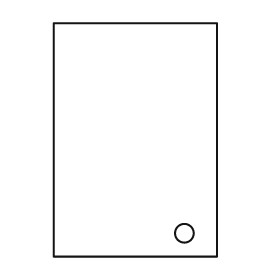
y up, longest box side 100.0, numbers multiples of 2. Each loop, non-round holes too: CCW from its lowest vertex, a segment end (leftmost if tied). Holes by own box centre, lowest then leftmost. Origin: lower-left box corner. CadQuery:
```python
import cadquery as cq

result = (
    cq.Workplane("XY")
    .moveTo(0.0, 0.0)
    .lineTo(70.0, 0.0)
    .lineTo(70.0, 100.0)
    .lineTo(0.0, 100.0)
    .close()
    .moveTo(56.0, 10.0)
    .circle(4.0)
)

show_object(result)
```